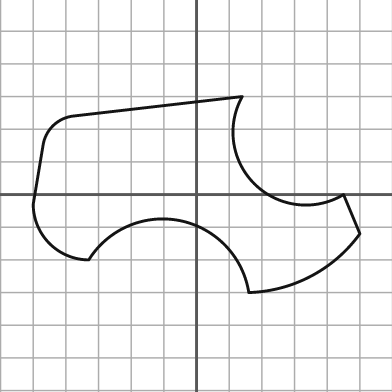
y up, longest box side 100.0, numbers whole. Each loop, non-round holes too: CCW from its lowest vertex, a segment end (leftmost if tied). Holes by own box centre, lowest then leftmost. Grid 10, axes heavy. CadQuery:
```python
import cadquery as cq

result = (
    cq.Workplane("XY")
    .moveTo(16.0, -30.0)
    .threePointArc((35.0, -25.0), (50.0, -12.0))
    .lineTo(45.0, 0.0)
    .threePointArc((18.0, 3.0), (14.0, 30.0))
    .lineTo(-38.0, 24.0)
    .threePointArc((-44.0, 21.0), (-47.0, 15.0))
    .lineTo(-50.0, -3.0)
    .threePointArc((-45.0, -15.0), (-33.0, -20.0))
    .threePointArc((-5.0, -8.0), (16.0, -30.0))
    .close()
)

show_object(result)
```